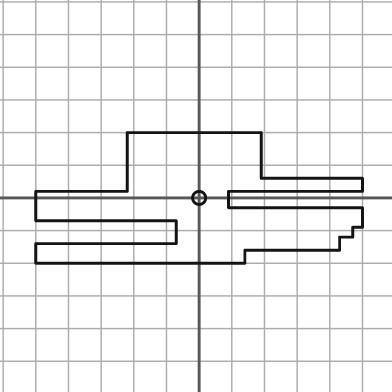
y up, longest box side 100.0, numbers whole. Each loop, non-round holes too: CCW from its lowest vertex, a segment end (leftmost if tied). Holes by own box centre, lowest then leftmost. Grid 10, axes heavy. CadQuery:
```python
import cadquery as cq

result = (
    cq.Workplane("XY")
    .moveTo(-50.0, -20.0)
    .lineTo(14.0, -20.0)
    .lineTo(14.0, -16.0)
    .lineTo(43.0, -16.0)
    .lineTo(43.0, -12.0)
    .lineTo(47.0, -12.0)
    .lineTo(47.0, -9.0)
    .lineTo(50.0, -9.0)
    .lineTo(50.0, -3.0)
    .lineTo(9.0, -3.0)
    .lineTo(9.0, 2.0)
    .lineTo(50.0, 2.0)
    .lineTo(50.0, 6.0)
    .lineTo(19.0, 6.0)
    .lineTo(19.0, 20.0)
    .lineTo(-22.0, 20.0)
    .lineTo(-22.0, 2.0)
    .lineTo(-50.0, 2.0)
    .lineTo(-50.0, -7.0)
    .lineTo(-7.0, -7.0)
    .lineTo(-7.0, -14.0)
    .lineTo(-50.0, -14.0)
    .close()
    .moveTo(0.0, 0.0)
    .circle(2.0)
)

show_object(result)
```